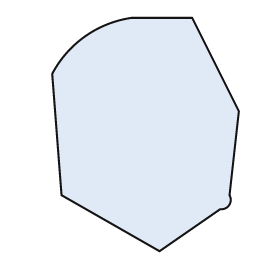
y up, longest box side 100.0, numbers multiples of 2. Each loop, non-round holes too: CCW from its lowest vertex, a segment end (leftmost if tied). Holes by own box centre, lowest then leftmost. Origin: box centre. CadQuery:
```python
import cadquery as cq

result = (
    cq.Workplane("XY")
    .moveTo(6.0, -50.0)
    .lineTo(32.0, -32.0)
    .threePointArc((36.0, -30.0), (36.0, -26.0))
    .lineTo(40.0, 10.0)
    .lineTo(20.0, 50.0)
    .lineTo(-6.0, 50.0)
    .threePointArc((-26.0, 42.0), (-40.0, 26.0))
    .lineTo(-36.0, -26.0)
    .close()
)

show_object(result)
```